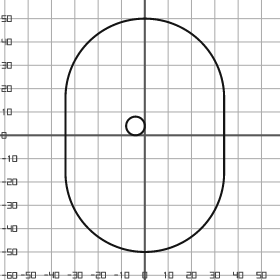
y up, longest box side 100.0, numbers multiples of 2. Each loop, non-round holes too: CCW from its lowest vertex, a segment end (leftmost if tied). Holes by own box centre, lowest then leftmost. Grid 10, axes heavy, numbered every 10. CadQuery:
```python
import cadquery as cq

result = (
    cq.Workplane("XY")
    .moveTo(-34.0, -16.0)
    .threePointArc((0.0, -50.0), (34.0, -16.0))
    .lineTo(34.0, 16.0)
    .threePointArc((0.0, 50.0), (-34.0, 16.0))
    .close()
    .moveTo(-4.0, 4.0)
    .circle(4.0)
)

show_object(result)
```